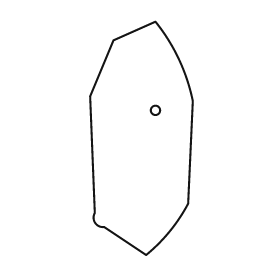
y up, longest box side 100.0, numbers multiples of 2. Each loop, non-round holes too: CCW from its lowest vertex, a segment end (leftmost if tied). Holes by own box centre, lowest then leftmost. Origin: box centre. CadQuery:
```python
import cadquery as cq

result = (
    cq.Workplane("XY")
    .moveTo(2.0, -50.0)
    .threePointArc((12.0, -40.0), (20.0, -28.0))
    .lineTo(22.0, 16.0)
    .threePointArc((16.0, 34.0), (6.0, 50.0))
    .lineTo(-12.0, 42.0)
    .lineTo(-22.0, 18.0)
    .lineTo(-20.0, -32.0)
    .threePointArc((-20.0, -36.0), (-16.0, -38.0))
    .close()
    .moveTo(6.0, 12.0)
    .circle(2.0)
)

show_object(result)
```